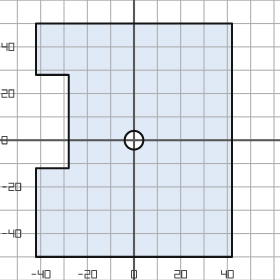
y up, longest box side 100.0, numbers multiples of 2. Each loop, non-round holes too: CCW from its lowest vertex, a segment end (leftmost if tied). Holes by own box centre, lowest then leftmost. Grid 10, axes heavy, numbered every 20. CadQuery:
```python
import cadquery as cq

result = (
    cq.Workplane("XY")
    .moveTo(-42.0, -50.0)
    .lineTo(42.0, -50.0)
    .lineTo(42.0, 50.0)
    .lineTo(-42.0, 50.0)
    .lineTo(-42.0, 28.0)
    .lineTo(-28.0, 28.0)
    .lineTo(-28.0, -12.0)
    .lineTo(-42.0, -12.0)
    .close()
    .moveTo(0.0, 0.0)
    .circle(4.0)
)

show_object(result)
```